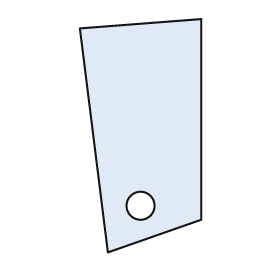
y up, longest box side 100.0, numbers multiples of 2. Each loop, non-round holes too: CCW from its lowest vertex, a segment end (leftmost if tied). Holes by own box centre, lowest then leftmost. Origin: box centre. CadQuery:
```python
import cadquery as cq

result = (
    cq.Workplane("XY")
    .moveTo(-14.0, -50.0)
    .lineTo(26.0, -36.0)
    .lineTo(26.0, 50.0)
    .lineTo(-26.0, 46.0)
    .close()
    .moveTo(0.0, -30.0)
    .circle(6.0)
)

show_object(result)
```